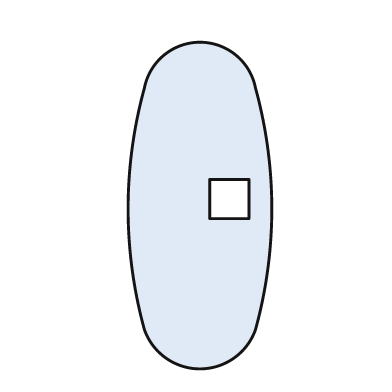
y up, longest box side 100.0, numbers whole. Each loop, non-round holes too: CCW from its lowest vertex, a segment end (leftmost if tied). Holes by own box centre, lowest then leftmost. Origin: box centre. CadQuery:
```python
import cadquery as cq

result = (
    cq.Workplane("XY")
    .moveTo(-17.0, -38.0)
    .threePointArc((0.0, -50.0), (17.0, -38.0))
    .threePointArc((22.0, -1.0), (17.0, 36.0))
    .threePointArc((0.0, 50.0), (-17.0, 36.0))
    .threePointArc((-22.0, -1.0), (-17.0, -38.0))
    .close()
    .moveTo(3.0, -4.0)
    .lineTo(15.0, -4.0)
    .lineTo(15.0, 8.0)
    .lineTo(3.0, 8.0)
    .close()
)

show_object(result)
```